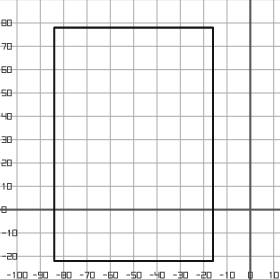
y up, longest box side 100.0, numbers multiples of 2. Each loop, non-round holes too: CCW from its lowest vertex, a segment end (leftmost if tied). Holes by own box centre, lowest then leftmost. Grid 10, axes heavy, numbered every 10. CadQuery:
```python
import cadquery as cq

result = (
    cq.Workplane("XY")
    .moveTo(-84.0, -22.0)
    .lineTo(-16.0, -22.0)
    .lineTo(-16.0, 78.0)
    .lineTo(-84.0, 78.0)
    .close()
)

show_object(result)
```